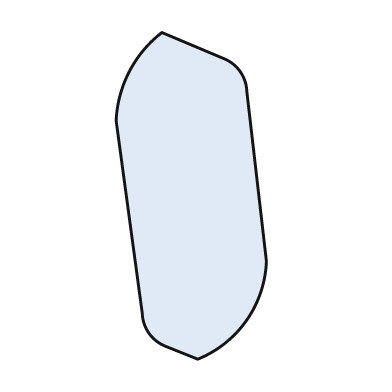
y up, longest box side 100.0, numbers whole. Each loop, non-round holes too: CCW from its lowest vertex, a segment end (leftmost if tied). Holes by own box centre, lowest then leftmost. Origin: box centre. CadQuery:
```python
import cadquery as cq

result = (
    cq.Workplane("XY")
    .moveTo(2.0, -50.0)
    .threePointArc((17.0, -38.0), (23.0, -20.0))
    .lineTo(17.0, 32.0)
    .threePointArc((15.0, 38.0), (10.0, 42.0))
    .lineTo(-9.0, 50.0)
    .threePointArc((-19.0, 38.0), (-23.0, 23.0))
    .lineTo(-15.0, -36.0)
    .threePointArc((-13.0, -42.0), (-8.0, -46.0))
    .close()
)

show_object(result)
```